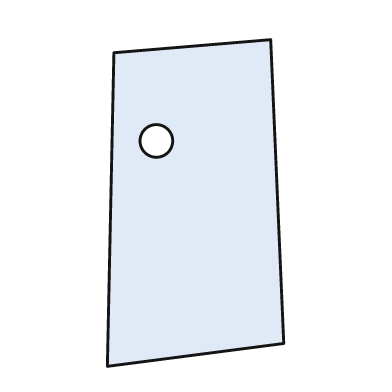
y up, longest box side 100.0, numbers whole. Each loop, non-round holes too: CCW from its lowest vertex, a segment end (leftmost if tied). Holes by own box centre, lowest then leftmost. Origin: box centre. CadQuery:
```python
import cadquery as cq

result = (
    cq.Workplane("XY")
    .moveTo(-27.0, -50.0)
    .lineTo(27.0, -43.0)
    .lineTo(23.0, 50.0)
    .lineTo(-25.0, 46.0)
    .close()
    .moveTo(-12.0, 19.0)
    .circle(5.0)
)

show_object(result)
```